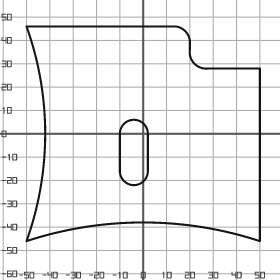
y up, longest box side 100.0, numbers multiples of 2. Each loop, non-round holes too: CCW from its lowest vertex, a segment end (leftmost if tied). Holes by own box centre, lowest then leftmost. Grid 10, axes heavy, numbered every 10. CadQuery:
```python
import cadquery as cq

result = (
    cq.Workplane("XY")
    .moveTo(-50.0, -46.0)
    .threePointArc((0.0, -38.0), (50.0, -46.0))
    .lineTo(50.0, 28.0)
    .lineTo(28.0, 28.0)
    .threePointArc((22.0, 30.0), (20.0, 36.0))
    .lineTo(20.0, 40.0)
    .threePointArc((18.0, 44.0), (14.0, 46.0))
    .lineTo(-50.0, 46.0)
    .threePointArc((-42.0, 0.0), (-50.0, -46.0))
    .close()
    .moveTo(-10.0, -16.0)
    .threePointArc((-4.0, -22.0), (2.0, -16.0))
    .lineTo(2.0, 0.0)
    .threePointArc((-4.0, 6.0), (-10.0, 0.0))
    .close()
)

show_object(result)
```